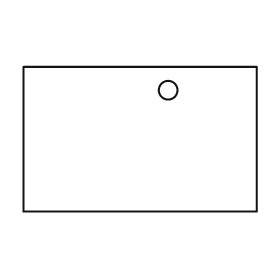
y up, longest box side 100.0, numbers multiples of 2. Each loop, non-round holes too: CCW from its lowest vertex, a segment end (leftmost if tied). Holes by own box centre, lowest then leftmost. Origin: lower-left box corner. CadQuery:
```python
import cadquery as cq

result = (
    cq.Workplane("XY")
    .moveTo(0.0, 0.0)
    .lineTo(100.0, 0.0)
    .lineTo(100.0, 62.0)
    .lineTo(0.0, 62.0)
    .close()
    .moveTo(62.0, 52.0)
    .circle(4.0)
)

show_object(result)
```